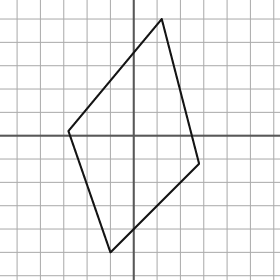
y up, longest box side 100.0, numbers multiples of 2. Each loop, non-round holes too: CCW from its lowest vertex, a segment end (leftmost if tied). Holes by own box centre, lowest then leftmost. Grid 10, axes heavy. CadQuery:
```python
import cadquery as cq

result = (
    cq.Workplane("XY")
    .moveTo(-10.0, -50.0)
    .lineTo(28.0, -12.0)
    .lineTo(12.0, 50.0)
    .lineTo(-28.0, 2.0)
    .close()
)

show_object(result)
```